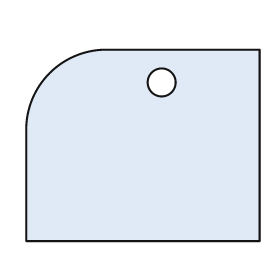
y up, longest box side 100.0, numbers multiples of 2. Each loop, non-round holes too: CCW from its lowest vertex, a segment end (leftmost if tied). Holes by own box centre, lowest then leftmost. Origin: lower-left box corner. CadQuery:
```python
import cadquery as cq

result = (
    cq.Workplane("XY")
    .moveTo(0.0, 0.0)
    .lineTo(100.0, 0.0)
    .lineTo(100.0, 82.0)
    .lineTo(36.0, 82.0)
    .threePointArc((10.0, 72.0), (0.0, 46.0))
    .close()
    .moveTo(58.0, 68.0)
    .circle(6.0)
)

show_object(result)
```